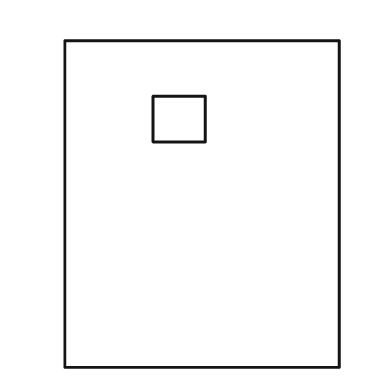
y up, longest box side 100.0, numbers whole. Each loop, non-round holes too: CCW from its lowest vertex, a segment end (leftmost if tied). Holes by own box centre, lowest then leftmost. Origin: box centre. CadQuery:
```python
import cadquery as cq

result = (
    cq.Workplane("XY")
    .moveTo(-42.0, -50.0)
    .lineTo(42.0, -50.0)
    .lineTo(42.0, 50.0)
    .lineTo(-42.0, 50.0)
    .close()
    .moveTo(-15.0, 19.0)
    .lineTo(1.0, 19.0)
    .lineTo(1.0, 33.0)
    .lineTo(-15.0, 33.0)
    .close()
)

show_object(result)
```